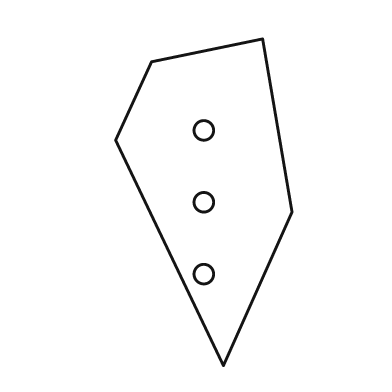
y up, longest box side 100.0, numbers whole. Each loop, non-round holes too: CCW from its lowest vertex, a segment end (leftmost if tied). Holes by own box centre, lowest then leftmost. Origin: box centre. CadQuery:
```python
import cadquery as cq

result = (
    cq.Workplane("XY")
    .moveTo(6.0, -50.0)
    .lineTo(27.0, -3.0)
    .lineTo(18.0, 50.0)
    .lineTo(-16.0, 43.0)
    .lineTo(-27.0, 19.0)
    .close()
    .moveTo(0.0, -22.0)
    .circle(3.0)
    .moveTo(0.0, 0.0)
    .circle(3.0)
    .moveTo(0.0, 22.0)
    .circle(3.0)
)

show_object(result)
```